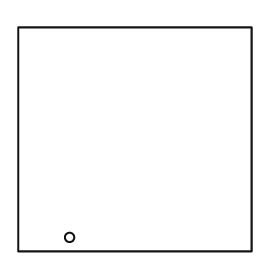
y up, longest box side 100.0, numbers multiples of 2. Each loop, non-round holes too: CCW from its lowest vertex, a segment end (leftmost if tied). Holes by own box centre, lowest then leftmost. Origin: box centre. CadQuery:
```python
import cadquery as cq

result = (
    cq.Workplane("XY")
    .moveTo(-50.0, -48.0)
    .lineTo(50.0, -48.0)
    .lineTo(50.0, 48.0)
    .lineTo(-50.0, 48.0)
    .close()
    .moveTo(-28.0, -42.0)
    .circle(2.0)
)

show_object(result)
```